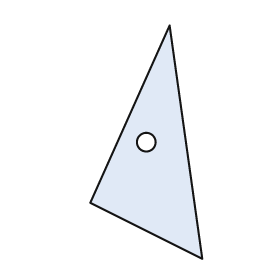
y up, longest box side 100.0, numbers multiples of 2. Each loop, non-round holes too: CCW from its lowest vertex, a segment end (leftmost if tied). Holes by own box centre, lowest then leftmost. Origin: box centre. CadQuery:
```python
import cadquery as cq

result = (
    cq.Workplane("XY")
    .moveTo(24.0, -50.0)
    .lineTo(10.0, 50.0)
    .lineTo(-24.0, -26.0)
    .close()
    .moveTo(0.0, 0.0)
    .circle(4.0)
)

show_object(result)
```